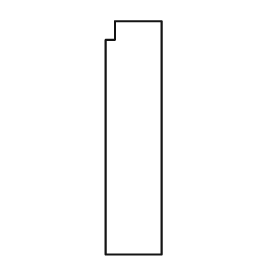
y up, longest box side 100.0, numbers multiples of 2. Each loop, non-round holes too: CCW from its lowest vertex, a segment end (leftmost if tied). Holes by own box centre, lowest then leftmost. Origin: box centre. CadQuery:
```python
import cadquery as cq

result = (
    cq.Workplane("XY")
    .moveTo(-12.0, -50.0)
    .lineTo(12.0, -50.0)
    .lineTo(12.0, 50.0)
    .lineTo(-8.0, 50.0)
    .lineTo(-8.0, 42.0)
    .lineTo(-12.0, 42.0)
    .close()
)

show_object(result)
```